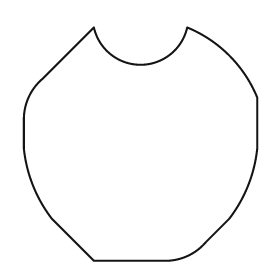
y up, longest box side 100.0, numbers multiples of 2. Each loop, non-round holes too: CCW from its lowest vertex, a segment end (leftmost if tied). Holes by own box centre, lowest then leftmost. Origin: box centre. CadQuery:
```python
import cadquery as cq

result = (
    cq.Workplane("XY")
    .moveTo(-20.0, -50.0)
    .lineTo(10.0, -50.0)
    .threePointArc((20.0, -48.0), (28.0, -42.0))
    .lineTo(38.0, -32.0)
    .threePointArc((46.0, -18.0), (50.0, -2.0))
    .lineTo(50.0, 20.0)
    .threePointArc((38.0, 38.0), (20.0, 50.0))
    .threePointArc((0.0, 34.0), (-20.0, 50.0))
    .lineTo(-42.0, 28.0)
    .threePointArc((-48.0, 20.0), (-50.0, 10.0))
    .lineTo(-50.0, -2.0)
    .threePointArc((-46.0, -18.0), (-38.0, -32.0))
    .close()
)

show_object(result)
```